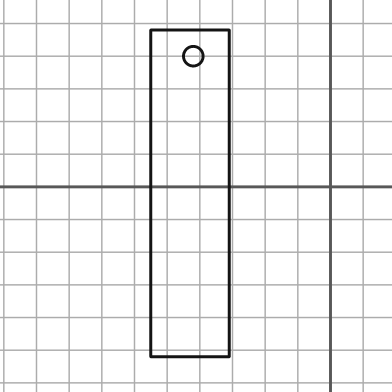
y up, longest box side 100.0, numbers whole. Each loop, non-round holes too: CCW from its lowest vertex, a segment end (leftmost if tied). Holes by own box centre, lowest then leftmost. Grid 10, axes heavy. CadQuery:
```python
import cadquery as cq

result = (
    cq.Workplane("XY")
    .moveTo(-55.0, -52.0)
    .lineTo(-31.0, -52.0)
    .lineTo(-31.0, 48.0)
    .lineTo(-55.0, 48.0)
    .close()
    .moveTo(-42.0, 40.0)
    .circle(3.0)
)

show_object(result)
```